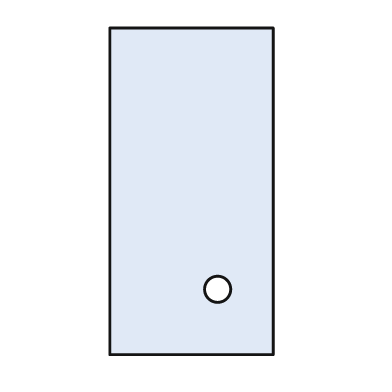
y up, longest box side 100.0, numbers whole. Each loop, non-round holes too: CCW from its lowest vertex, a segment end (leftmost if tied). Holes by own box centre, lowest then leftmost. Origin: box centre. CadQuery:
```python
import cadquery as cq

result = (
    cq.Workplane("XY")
    .moveTo(-25.0, -50.0)
    .lineTo(25.0, -50.0)
    .lineTo(25.0, 50.0)
    .lineTo(-25.0, 50.0)
    .close()
    .moveTo(8.0, -30.0)
    .circle(4.0)
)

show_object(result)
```